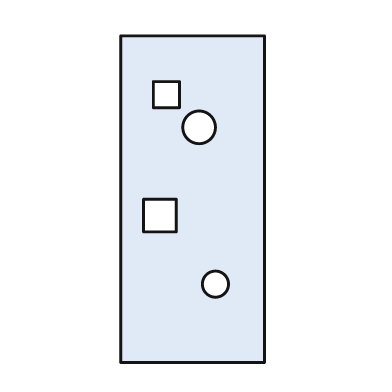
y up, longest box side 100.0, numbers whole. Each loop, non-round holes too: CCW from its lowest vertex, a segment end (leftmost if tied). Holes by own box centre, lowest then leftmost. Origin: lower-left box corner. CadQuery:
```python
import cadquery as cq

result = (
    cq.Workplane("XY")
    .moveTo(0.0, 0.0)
    .lineTo(44.0, 0.0)
    .lineTo(44.0, 100.0)
    .lineTo(0.0, 100.0)
    .close()
    .moveTo(29.0, 24.0)
    .circle(4.0)
    .moveTo(7.0, 40.0)
    .lineTo(17.0, 40.0)
    .lineTo(17.0, 50.0)
    .lineTo(7.0, 50.0)
    .close()
    .moveTo(24.0, 72.0)
    .circle(5.0)
    .moveTo(10.0, 78.0)
    .lineTo(18.0, 78.0)
    .lineTo(18.0, 86.0)
    .lineTo(10.0, 86.0)
    .close()
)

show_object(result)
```